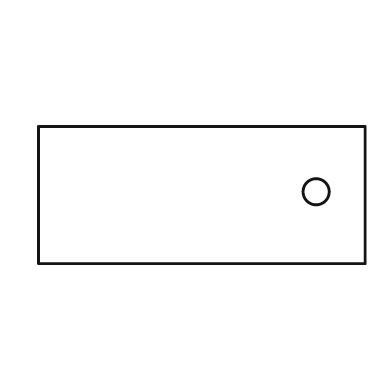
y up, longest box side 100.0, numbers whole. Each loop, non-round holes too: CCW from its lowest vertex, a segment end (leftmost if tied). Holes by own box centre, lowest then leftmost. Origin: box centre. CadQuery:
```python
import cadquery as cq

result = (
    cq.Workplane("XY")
    .moveTo(-50.0, -21.0)
    .lineTo(50.0, -21.0)
    .lineTo(50.0, 21.0)
    .lineTo(-50.0, 21.0)
    .close()
    .moveTo(35.0, 1.0)
    .circle(4.0)
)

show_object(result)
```